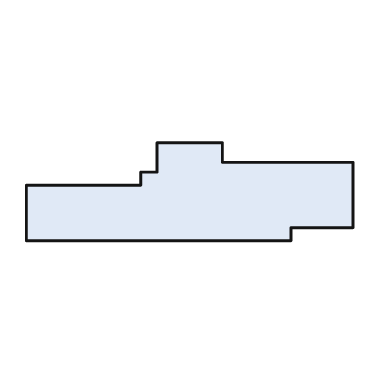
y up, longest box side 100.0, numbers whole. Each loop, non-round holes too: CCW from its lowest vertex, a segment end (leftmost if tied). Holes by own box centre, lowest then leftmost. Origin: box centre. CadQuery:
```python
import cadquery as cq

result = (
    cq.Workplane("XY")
    .moveTo(-50.0, -15.0)
    .lineTo(31.0, -15.0)
    .lineTo(31.0, -11.0)
    .lineTo(50.0, -11.0)
    .lineTo(50.0, 9.0)
    .lineTo(10.0, 9.0)
    .lineTo(10.0, 15.0)
    .lineTo(-10.0, 15.0)
    .lineTo(-10.0, 6.0)
    .lineTo(-15.0, 6.0)
    .lineTo(-15.0, 2.0)
    .lineTo(-50.0, 2.0)
    .close()
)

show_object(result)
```